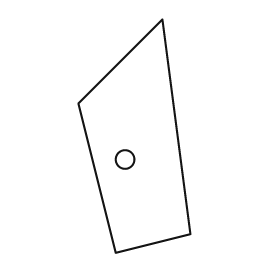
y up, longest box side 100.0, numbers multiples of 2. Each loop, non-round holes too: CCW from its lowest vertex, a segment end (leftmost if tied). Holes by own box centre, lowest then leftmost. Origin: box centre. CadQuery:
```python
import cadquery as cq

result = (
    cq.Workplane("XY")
    .moveTo(-8.0, -50.0)
    .lineTo(24.0, -42.0)
    .lineTo(12.0, 50.0)
    .lineTo(-24.0, 14.0)
    .close()
    .moveTo(-4.0, -10.0)
    .circle(4.0)
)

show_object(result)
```